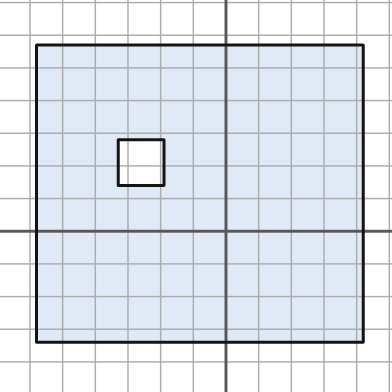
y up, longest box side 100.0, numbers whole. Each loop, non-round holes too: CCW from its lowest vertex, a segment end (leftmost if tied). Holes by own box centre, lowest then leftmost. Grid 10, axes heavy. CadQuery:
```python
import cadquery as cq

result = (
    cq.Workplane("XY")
    .moveTo(-58.0, -34.0)
    .lineTo(42.0, -34.0)
    .lineTo(42.0, 57.0)
    .lineTo(-58.0, 57.0)
    .close()
    .moveTo(-33.0, 14.0)
    .lineTo(-19.0, 14.0)
    .lineTo(-19.0, 28.0)
    .lineTo(-33.0, 28.0)
    .close()
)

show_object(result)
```